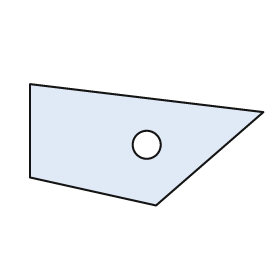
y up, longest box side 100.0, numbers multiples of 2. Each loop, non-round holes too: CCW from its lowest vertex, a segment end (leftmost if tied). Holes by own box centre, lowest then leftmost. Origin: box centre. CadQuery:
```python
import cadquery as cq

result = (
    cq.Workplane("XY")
    .moveTo(4.0, -26.0)
    .lineTo(50.0, 14.0)
    .lineTo(-50.0, 26.0)
    .lineTo(-50.0, -14.0)
    .close()
    .moveTo(0.0, 0.0)
    .circle(6.0)
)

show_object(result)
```